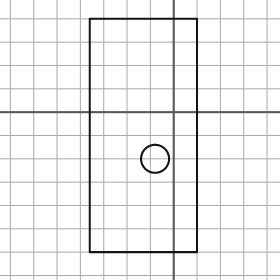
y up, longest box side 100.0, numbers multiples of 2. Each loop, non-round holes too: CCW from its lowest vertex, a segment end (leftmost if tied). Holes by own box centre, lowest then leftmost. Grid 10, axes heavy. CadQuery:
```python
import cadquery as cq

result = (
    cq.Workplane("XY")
    .moveTo(-36.0, -60.0)
    .lineTo(10.0, -60.0)
    .lineTo(10.0, 40.0)
    .lineTo(-36.0, 40.0)
    .close()
    .moveTo(-8.0, -20.0)
    .circle(6.0)
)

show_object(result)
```